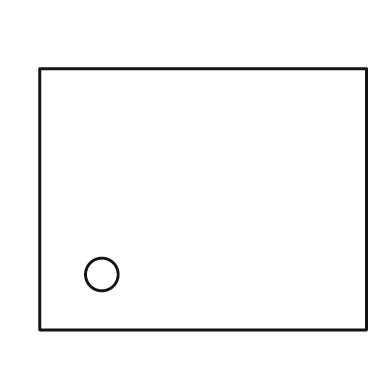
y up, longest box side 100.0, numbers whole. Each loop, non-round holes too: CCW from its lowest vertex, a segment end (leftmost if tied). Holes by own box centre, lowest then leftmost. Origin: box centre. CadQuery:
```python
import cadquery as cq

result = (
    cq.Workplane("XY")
    .moveTo(-50.0, -40.0)
    .lineTo(50.0, -40.0)
    .lineTo(50.0, 40.0)
    .lineTo(-50.0, 40.0)
    .close()
    .moveTo(-31.0, -23.0)
    .circle(5.0)
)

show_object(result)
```